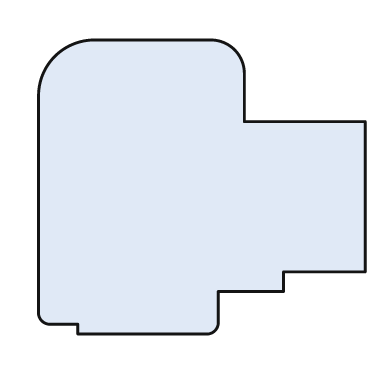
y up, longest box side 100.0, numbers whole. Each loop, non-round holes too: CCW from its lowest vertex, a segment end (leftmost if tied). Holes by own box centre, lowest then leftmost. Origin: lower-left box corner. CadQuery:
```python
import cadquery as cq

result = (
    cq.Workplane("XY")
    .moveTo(12.0, 0.0)
    .lineTo(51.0, 0.0)
    .threePointArc((54.0, 1.0), (55.0, 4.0))
    .lineTo(55.0, 13.0)
    .lineTo(75.0, 13.0)
    .lineTo(75.0, 19.0)
    .lineTo(100.0, 19.0)
    .lineTo(100.0, 65.0)
    .lineTo(63.0, 65.0)
    .lineTo(63.0, 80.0)
    .threePointArc((60.0, 87.0), (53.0, 90.0))
    .lineTo(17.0, 90.0)
    .threePointArc((5.0, 85.0), (0.0, 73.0))
    .lineTo(0.0, 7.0)
    .threePointArc((1.0, 4.0), (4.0, 3.0))
    .lineTo(12.0, 3.0)
    .close()
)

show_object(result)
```